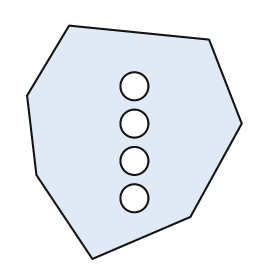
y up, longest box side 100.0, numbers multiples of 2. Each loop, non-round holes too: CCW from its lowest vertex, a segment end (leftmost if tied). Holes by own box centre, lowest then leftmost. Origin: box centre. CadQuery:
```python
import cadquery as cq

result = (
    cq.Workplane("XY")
    .moveTo(-18.0, -50.0)
    .lineTo(24.0, -32.0)
    .lineTo(46.0, 8.0)
    .lineTo(32.0, 44.0)
    .lineTo(-28.0, 50.0)
    .lineTo(-46.0, 20.0)
    .lineTo(-42.0, -14.0)
    .close()
    .moveTo(0.0, -24.0)
    .circle(6.0)
    .moveTo(0.0, -8.0)
    .circle(6.0)
    .moveTo(0.0, 8.0)
    .circle(6.0)
    .moveTo(0.0, 24.0)
    .circle(6.0)
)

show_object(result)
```